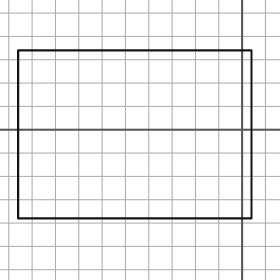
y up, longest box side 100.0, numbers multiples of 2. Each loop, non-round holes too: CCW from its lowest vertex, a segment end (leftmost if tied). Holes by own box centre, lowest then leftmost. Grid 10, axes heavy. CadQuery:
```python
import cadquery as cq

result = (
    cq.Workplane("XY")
    .moveTo(-96.0, -38.0)
    .lineTo(4.0, -38.0)
    .lineTo(4.0, 34.0)
    .lineTo(-96.0, 34.0)
    .close()
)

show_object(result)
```